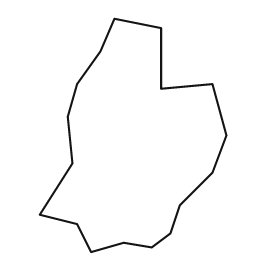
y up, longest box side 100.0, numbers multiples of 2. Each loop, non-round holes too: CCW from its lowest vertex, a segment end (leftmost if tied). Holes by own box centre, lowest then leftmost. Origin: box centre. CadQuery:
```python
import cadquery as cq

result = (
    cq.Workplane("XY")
    .moveTo(-18.0, -50.0)
    .lineTo(-4.0, -46.0)
    .lineTo(8.0, -48.0)
    .lineTo(16.0, -42.0)
    .lineTo(20.0, -30.0)
    .lineTo(34.0, -16.0)
    .lineTo(40.0, 0.0)
    .lineTo(34.0, 22.0)
    .lineTo(12.0, 20.0)
    .lineTo(12.0, 46.0)
    .lineTo(-8.0, 50.0)
    .lineTo(-14.0, 36.0)
    .lineTo(-24.0, 22.0)
    .lineTo(-28.0, 8.0)
    .lineTo(-26.0, -12.0)
    .lineTo(-40.0, -34.0)
    .lineTo(-24.0, -38.0)
    .close()
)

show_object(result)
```